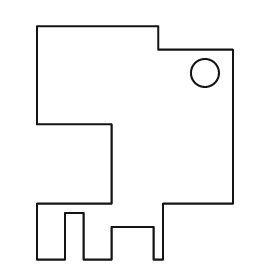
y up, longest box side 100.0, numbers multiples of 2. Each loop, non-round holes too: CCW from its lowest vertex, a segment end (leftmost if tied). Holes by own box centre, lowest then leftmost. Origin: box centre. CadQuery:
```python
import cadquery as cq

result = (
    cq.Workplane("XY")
    .moveTo(-42.0, -50.0)
    .lineTo(-30.0, -50.0)
    .lineTo(-30.0, -30.0)
    .lineTo(-22.0, -30.0)
    .lineTo(-22.0, -50.0)
    .lineTo(-10.0, -50.0)
    .lineTo(-10.0, -36.0)
    .lineTo(8.0, -36.0)
    .lineTo(8.0, -50.0)
    .lineTo(12.0, -50.0)
    .lineTo(12.0, -26.0)
    .lineTo(42.0, -26.0)
    .lineTo(42.0, 40.0)
    .lineTo(10.0, 40.0)
    .lineTo(10.0, 50.0)
    .lineTo(-42.0, 50.0)
    .lineTo(-42.0, 8.0)
    .lineTo(-10.0, 8.0)
    .lineTo(-10.0, -26.0)
    .lineTo(-42.0, -26.0)
    .close()
    .moveTo(30.0, 30.0)
    .circle(6.0)
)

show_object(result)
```